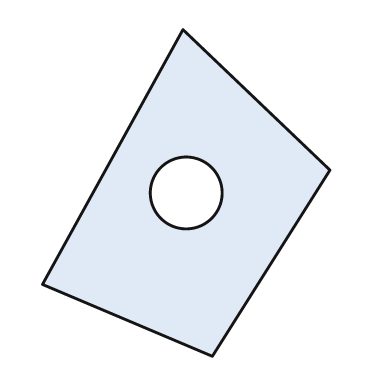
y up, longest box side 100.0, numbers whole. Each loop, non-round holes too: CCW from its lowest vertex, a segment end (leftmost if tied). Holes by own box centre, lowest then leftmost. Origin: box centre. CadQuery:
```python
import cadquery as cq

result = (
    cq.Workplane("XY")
    .moveTo(8.0, -50.0)
    .lineTo(44.0, 7.0)
    .lineTo(-1.0, 50.0)
    .lineTo(-44.0, -28.0)
    .close()
    .moveTo(0.0, 0.0)
    .circle(11.0)
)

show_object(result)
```